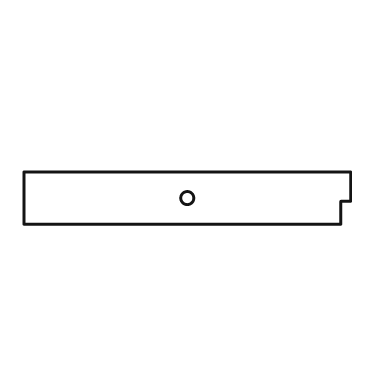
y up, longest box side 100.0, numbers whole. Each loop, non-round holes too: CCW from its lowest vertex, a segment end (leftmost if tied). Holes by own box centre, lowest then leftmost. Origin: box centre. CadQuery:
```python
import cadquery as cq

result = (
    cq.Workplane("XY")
    .moveTo(-50.0, -8.0)
    .lineTo(47.0, -8.0)
    .lineTo(47.0, -1.0)
    .lineTo(50.0, -1.0)
    .lineTo(50.0, 8.0)
    .lineTo(-50.0, 8.0)
    .close()
    .moveTo(0.0, 0.0)
    .circle(2.0)
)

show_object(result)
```